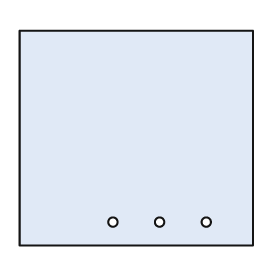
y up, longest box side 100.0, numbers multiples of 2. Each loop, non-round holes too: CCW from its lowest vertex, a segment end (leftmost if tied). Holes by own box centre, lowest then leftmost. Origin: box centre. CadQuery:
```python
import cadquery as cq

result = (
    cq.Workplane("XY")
    .moveTo(-50.0, -46.0)
    .lineTo(50.0, -46.0)
    .lineTo(50.0, 46.0)
    .lineTo(-50.0, 46.0)
    .close()
    .moveTo(-10.0, -36.0)
    .circle(2.0)
    .moveTo(10.0, -36.0)
    .circle(2.0)
    .moveTo(30.0, -36.0)
    .circle(2.0)
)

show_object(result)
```